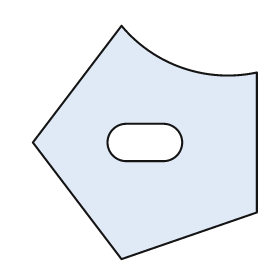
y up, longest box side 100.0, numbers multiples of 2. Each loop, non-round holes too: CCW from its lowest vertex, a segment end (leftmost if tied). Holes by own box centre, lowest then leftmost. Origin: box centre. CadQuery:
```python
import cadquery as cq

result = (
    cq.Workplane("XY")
    .moveTo(-10.0, -50.0)
    .lineTo(48.0, -30.0)
    .lineTo(48.0, 30.0)
    .threePointArc((16.0, 32.0), (-10.0, 50.0))
    .lineTo(-48.0, 0.0)
    .close()
    .moveTo(-8.0, -8.0)
    .lineTo(8.0, -8.0)
    .threePointArc((16.0, 0.0), (8.0, 8.0))
    .lineTo(-8.0, 8.0)
    .threePointArc((-16.0, 0.0), (-8.0, -8.0))
    .close()
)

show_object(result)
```